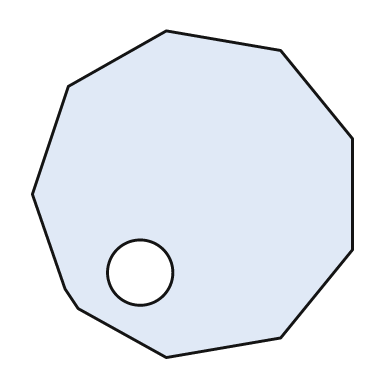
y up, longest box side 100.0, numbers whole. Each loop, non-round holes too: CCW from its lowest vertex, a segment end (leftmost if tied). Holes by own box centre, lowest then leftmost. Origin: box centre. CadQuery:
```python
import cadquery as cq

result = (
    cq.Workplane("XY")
    .moveTo(-8.0, -50.0)
    .lineTo(27.0, -44.0)
    .lineTo(49.0, -17.0)
    .lineTo(49.0, 17.0)
    .lineTo(27.0, 44.0)
    .lineTo(-8.0, 50.0)
    .lineTo(-38.0, 33.0)
    .lineTo(-49.0, 0.0)
    .lineTo(-39.0, -29.0)
    .lineTo(-35.0, -35.0)
    .close()
    .moveTo(-16.0, -24.0)
    .circle(10.0)
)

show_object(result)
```